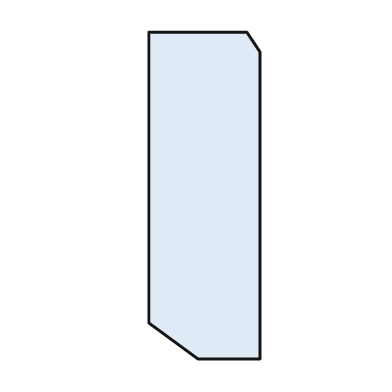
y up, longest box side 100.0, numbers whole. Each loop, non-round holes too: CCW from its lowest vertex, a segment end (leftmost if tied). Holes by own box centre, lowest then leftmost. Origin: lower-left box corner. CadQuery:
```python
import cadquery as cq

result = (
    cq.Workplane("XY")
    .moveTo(15.0, 0.0)
    .lineTo(34.0, 0.0)
    .lineTo(34.0, 94.0)
    .lineTo(30.0, 100.0)
    .lineTo(0.0, 100.0)
    .lineTo(0.0, 11.0)
    .close()
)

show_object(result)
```